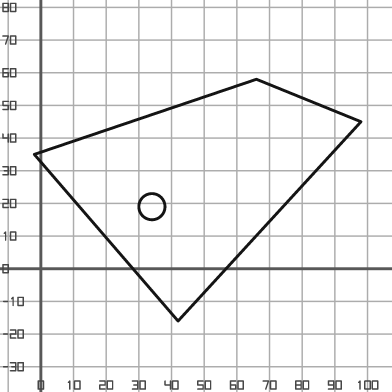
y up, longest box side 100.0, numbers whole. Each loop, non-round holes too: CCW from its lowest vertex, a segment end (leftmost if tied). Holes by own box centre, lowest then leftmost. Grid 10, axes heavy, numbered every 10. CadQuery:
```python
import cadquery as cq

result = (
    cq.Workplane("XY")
    .moveTo(42.0, -16.0)
    .lineTo(98.0, 45.0)
    .lineTo(66.0, 58.0)
    .lineTo(-2.0, 35.0)
    .close()
    .moveTo(34.0, 19.0)
    .circle(4.0)
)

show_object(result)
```